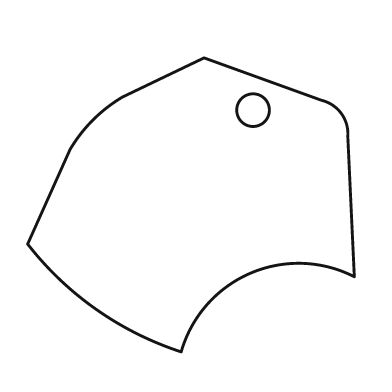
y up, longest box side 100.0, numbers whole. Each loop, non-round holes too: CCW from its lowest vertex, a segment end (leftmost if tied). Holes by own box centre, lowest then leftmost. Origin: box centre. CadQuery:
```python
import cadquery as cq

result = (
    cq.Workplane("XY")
    .moveTo(-3.0, -45.0)
    .threePointArc((18.0, -21.0), (50.0, -22.0))
    .lineTo(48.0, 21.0)
    .threePointArc((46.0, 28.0), (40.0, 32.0))
    .lineTo(4.0, 45.0)
    .lineTo(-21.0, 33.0)
    .threePointArc((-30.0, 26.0), (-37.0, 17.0))
    .lineTo(-50.0, -12.0)
    .threePointArc((-29.0, -32.0), (-3.0, -45.0))
    .close()
    .moveTo(19.0, 29.0)
    .circle(5.0)
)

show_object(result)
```